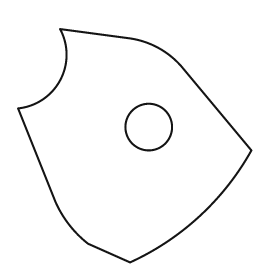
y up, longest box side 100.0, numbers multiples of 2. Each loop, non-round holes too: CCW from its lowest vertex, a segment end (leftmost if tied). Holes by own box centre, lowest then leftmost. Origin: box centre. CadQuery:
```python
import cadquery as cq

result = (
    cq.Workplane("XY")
    .moveTo(-2.0, -50.0)
    .threePointArc((28.0, -30.0), (50.0, -2.0))
    .lineTo(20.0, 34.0)
    .threePointArc((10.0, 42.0), (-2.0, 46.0))
    .lineTo(-32.0, 50.0)
    .threePointArc((-32.0, 28.0), (-50.0, 16.0))
    .lineTo(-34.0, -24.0)
    .threePointArc((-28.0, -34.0), (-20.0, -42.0))
    .close()
    .moveTo(6.0, 8.0)
    .circle(10.0)
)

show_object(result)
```